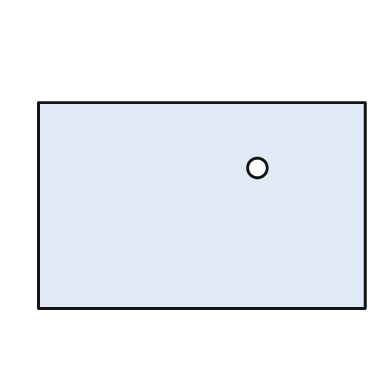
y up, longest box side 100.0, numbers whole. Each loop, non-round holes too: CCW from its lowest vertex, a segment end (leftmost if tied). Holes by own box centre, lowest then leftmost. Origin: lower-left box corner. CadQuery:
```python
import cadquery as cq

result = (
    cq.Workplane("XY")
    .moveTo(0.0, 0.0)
    .lineTo(100.0, 0.0)
    .lineTo(100.0, 63.0)
    .lineTo(0.0, 63.0)
    .close()
    .moveTo(67.0, 43.0)
    .circle(3.0)
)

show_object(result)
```